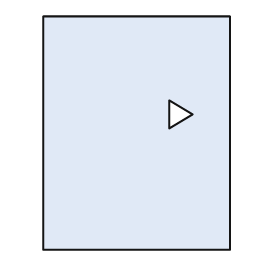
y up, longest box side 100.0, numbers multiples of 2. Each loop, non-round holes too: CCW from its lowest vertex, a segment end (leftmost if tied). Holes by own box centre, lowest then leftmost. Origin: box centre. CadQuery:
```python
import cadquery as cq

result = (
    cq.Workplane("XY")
    .moveTo(-40.0, -50.0)
    .lineTo(40.0, -50.0)
    .lineTo(40.0, 50.0)
    .lineTo(-40.0, 50.0)
    .close()
    .moveTo(14.0, 2.0)
    .lineTo(24.0, 8.0)
    .lineTo(14.0, 14.0)
    .close()
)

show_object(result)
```